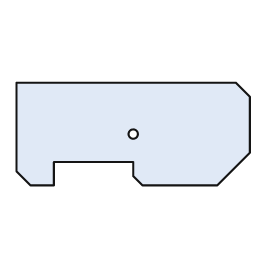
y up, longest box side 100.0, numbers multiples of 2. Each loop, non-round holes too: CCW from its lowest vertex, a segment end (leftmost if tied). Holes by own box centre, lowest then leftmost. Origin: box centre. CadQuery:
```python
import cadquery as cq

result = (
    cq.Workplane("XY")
    .moveTo(-44.0, -22.0)
    .lineTo(-34.0, -22.0)
    .lineTo(-34.0, -12.0)
    .lineTo(0.0, -12.0)
    .lineTo(0.0, -18.0)
    .lineTo(4.0, -22.0)
    .lineTo(36.0, -22.0)
    .lineTo(50.0, -8.0)
    .lineTo(50.0, 16.0)
    .lineTo(44.0, 22.0)
    .lineTo(-50.0, 22.0)
    .lineTo(-50.0, -16.0)
    .close()
    .moveTo(0.0, 0.0)
    .circle(2.0)
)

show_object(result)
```